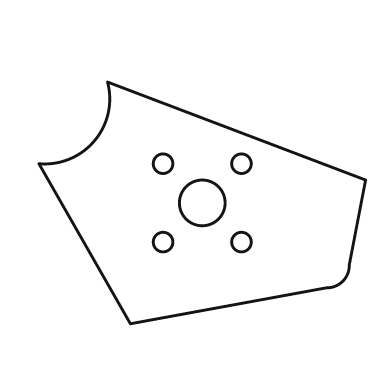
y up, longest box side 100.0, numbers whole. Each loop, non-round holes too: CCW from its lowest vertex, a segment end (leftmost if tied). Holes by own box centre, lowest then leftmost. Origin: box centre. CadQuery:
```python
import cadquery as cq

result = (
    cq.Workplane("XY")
    .moveTo(-22.0, -37.0)
    .lineTo(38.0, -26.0)
    .threePointArc((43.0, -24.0), (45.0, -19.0))
    .lineTo(50.0, 7.0)
    .lineTo(-29.0, 37.0)
    .threePointArc((-33.0, 19.0), (-50.0, 12.0))
    .close()
    .moveTo(-12.0, -12.0)
    .circle(3.0)
    .moveTo(12.0, -12.0)
    .circle(3.0)
    .moveTo(0.0, 0.0)
    .circle(7.0)
    .moveTo(-12.0, 12.0)
    .circle(3.0)
    .moveTo(12.0, 12.0)
    .circle(3.0)
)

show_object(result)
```